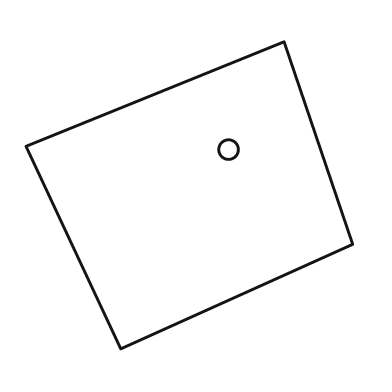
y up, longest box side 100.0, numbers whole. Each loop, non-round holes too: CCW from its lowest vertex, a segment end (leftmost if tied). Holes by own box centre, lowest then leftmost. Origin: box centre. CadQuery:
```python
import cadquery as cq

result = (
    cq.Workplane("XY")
    .moveTo(-21.0, -47.0)
    .lineTo(50.0, -15.0)
    .lineTo(29.0, 47.0)
    .lineTo(-50.0, 15.0)
    .close()
    .moveTo(12.0, 14.0)
    .circle(3.0)
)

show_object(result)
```